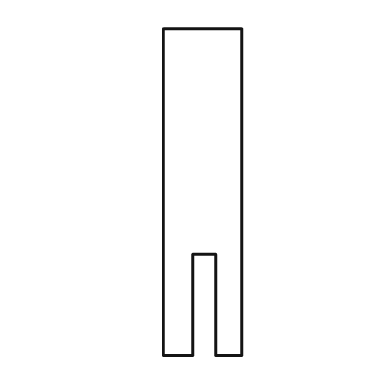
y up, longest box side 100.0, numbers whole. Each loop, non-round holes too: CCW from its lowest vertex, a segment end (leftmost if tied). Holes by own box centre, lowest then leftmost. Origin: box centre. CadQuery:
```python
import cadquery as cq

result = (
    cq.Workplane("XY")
    .moveTo(-12.0, -50.0)
    .lineTo(-3.0, -50.0)
    .lineTo(-3.0, -19.0)
    .lineTo(4.0, -19.0)
    .lineTo(4.0, -50.0)
    .lineTo(12.0, -50.0)
    .lineTo(12.0, 50.0)
    .lineTo(-12.0, 50.0)
    .close()
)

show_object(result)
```